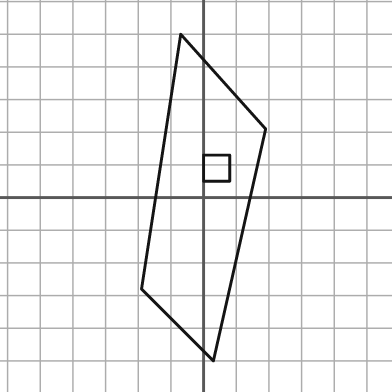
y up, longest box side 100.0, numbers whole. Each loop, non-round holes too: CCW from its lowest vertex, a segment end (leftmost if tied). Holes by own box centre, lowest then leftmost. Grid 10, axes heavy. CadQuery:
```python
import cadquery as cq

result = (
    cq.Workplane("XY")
    .moveTo(3.0, -50.0)
    .lineTo(19.0, 21.0)
    .lineTo(-7.0, 50.0)
    .lineTo(-19.0, -28.0)
    .close()
    .moveTo(0.0, 5.0)
    .lineTo(8.0, 5.0)
    .lineTo(8.0, 13.0)
    .lineTo(0.0, 13.0)
    .close()
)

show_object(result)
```